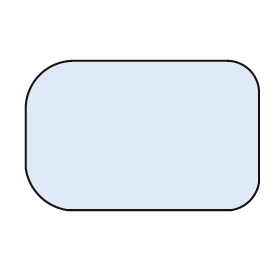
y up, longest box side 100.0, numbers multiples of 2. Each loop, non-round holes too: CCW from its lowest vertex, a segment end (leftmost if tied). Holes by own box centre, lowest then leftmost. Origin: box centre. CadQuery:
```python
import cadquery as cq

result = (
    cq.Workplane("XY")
    .moveTo(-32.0, -32.0)
    .lineTo(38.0, -32.0)
    .threePointArc((46.0, -28.0), (50.0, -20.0))
    .lineTo(50.0, 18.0)
    .threePointArc((46.0, 28.0), (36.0, 32.0))
    .lineTo(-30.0, 32.0)
    .threePointArc((-44.0, 26.0), (-50.0, 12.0))
    .lineTo(-50.0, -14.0)
    .threePointArc((-44.0, -26.0), (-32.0, -32.0))
    .close()
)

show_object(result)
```